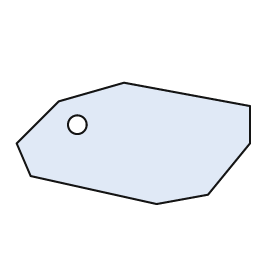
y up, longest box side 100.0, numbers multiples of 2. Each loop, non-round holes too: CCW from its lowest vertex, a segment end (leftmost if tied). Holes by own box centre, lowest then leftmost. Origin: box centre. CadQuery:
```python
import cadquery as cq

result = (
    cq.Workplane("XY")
    .moveTo(10.0, -26.0)
    .lineTo(32.0, -22.0)
    .lineTo(50.0, 0.0)
    .lineTo(50.0, 16.0)
    .lineTo(-4.0, 26.0)
    .lineTo(-32.0, 18.0)
    .lineTo(-50.0, 0.0)
    .lineTo(-44.0, -14.0)
    .close()
    .moveTo(-24.0, 8.0)
    .circle(4.0)
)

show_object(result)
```